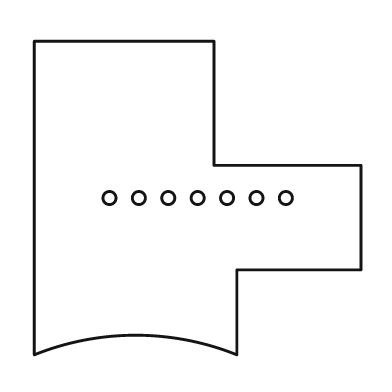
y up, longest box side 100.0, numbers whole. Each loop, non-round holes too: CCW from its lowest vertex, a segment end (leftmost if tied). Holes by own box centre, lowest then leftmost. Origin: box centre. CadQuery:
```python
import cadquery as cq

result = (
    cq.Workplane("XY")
    .moveTo(-50.0, -48.0)
    .threePointArc((-19.0, -42.0), (12.0, -48.0))
    .lineTo(12.0, -22.0)
    .lineTo(50.0, -22.0)
    .lineTo(50.0, 10.0)
    .lineTo(5.0, 10.0)
    .lineTo(5.0, 48.0)
    .lineTo(-50.0, 48.0)
    .close()
    .moveTo(-27.0, 0.0)
    .circle(2.0)
    .moveTo(-18.0, 0.0)
    .circle(2.0)
    .moveTo(-9.0, 0.0)
    .circle(2.0)
    .moveTo(0.0, 0.0)
    .circle(2.0)
    .moveTo(9.0, 0.0)
    .circle(2.0)
    .moveTo(18.0, 0.0)
    .circle(2.0)
    .moveTo(27.0, 0.0)
    .circle(2.0)
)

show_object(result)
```